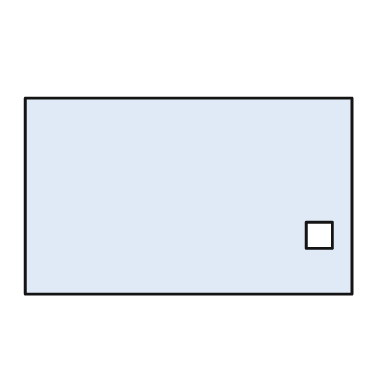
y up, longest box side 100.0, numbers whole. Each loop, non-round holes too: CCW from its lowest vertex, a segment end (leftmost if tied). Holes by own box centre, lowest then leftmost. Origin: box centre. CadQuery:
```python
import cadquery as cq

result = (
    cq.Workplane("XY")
    .moveTo(-50.0, -30.0)
    .lineTo(50.0, -30.0)
    .lineTo(50.0, 30.0)
    .lineTo(-50.0, 30.0)
    .close()
    .moveTo(36.0, -16.0)
    .lineTo(44.0, -16.0)
    .lineTo(44.0, -8.0)
    .lineTo(36.0, -8.0)
    .close()
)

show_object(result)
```